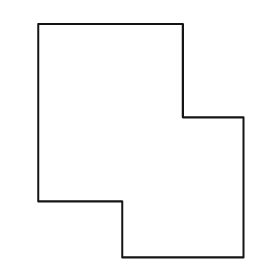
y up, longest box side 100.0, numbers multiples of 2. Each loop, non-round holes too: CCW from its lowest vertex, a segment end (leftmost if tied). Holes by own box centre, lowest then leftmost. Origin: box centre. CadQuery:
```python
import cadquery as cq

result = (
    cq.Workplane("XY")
    .moveTo(-8.0, -50.0)
    .lineTo(44.0, -50.0)
    .lineTo(44.0, 10.0)
    .lineTo(18.0, 10.0)
    .lineTo(18.0, 50.0)
    .lineTo(-44.0, 50.0)
    .lineTo(-44.0, -26.0)
    .lineTo(-8.0, -26.0)
    .close()
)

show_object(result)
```